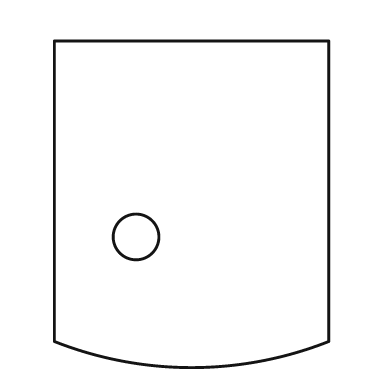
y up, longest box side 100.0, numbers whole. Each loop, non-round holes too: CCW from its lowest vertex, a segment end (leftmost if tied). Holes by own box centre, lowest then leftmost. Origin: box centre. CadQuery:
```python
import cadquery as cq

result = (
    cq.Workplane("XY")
    .moveTo(-42.0, -42.0)
    .threePointArc((0.0, -50.0), (42.0, -42.0))
    .lineTo(42.0, 50.0)
    .lineTo(-42.0, 50.0)
    .close()
    .moveTo(-17.0, -10.0)
    .circle(7.0)
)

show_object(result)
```